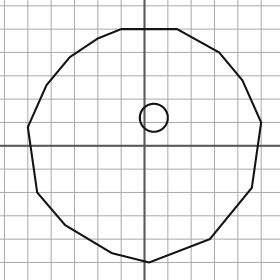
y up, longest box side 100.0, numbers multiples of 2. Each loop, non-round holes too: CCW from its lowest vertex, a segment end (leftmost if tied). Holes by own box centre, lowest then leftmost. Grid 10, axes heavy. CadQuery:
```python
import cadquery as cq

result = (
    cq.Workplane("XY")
    .moveTo(2.0, -50.0)
    .lineTo(28.0, -40.0)
    .lineTo(46.0, -18.0)
    .lineTo(50.0, 10.0)
    .lineTo(42.0, 28.0)
    .lineTo(32.0, 40.0)
    .lineTo(14.0, 50.0)
    .lineTo(-10.0, 50.0)
    .lineTo(-20.0, 46.0)
    .lineTo(-32.0, 38.0)
    .lineTo(-42.0, 26.0)
    .lineTo(-50.0, 8.0)
    .lineTo(-46.0, -20.0)
    .lineTo(-34.0, -34.0)
    .lineTo(-14.0, -46.0)
    .close()
    .moveTo(4.0, 12.0)
    .circle(6.0)
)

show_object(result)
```